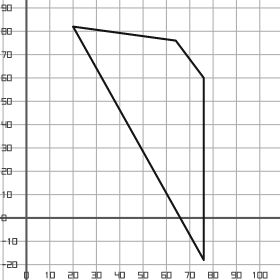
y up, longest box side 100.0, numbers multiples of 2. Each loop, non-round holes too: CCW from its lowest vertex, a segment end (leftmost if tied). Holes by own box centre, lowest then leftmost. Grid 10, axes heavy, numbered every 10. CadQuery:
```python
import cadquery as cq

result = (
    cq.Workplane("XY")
    .moveTo(76.0, -18.0)
    .lineTo(76.0, 60.0)
    .lineTo(64.0, 76.0)
    .lineTo(20.0, 82.0)
    .close()
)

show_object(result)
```